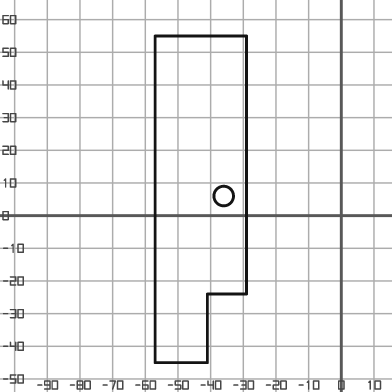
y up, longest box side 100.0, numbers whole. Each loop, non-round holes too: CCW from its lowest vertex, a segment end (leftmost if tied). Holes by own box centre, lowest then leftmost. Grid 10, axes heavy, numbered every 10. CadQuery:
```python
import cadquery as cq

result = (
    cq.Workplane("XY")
    .moveTo(-57.0, -45.0)
    .lineTo(-41.0, -45.0)
    .lineTo(-41.0, -24.0)
    .lineTo(-29.0, -24.0)
    .lineTo(-29.0, 55.0)
    .lineTo(-57.0, 55.0)
    .close()
    .moveTo(-36.0, 6.0)
    .circle(3.0)
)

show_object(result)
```